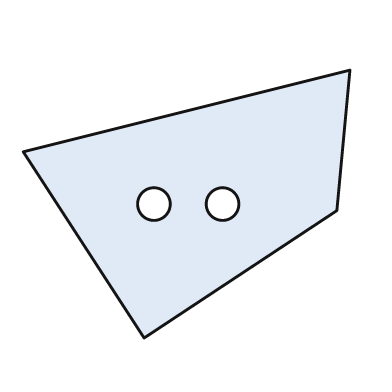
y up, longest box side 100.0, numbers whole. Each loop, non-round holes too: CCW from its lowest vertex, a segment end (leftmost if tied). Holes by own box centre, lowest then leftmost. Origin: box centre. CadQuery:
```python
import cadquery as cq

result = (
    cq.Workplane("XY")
    .moveTo(-13.0, -41.0)
    .lineTo(46.0, -2.0)
    .lineTo(50.0, 41.0)
    .lineTo(-50.0, 16.0)
    .close()
    .moveTo(-10.0, 0.0)
    .circle(5.0)
    .moveTo(11.0, 0.0)
    .circle(5.0)
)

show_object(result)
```